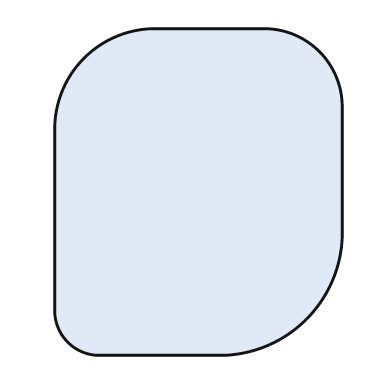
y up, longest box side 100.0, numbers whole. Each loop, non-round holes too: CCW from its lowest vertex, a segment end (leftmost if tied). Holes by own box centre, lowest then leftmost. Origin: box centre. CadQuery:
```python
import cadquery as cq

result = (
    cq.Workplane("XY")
    .moveTo(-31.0, -50.0)
    .lineTo(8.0, -50.0)
    .threePointArc((33.0, -39.0), (44.0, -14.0))
    .lineTo(44.0, 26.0)
    .threePointArc((37.0, 43.0), (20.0, 50.0))
    .lineTo(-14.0, 50.0)
    .threePointArc((-35.0, 41.0), (-44.0, 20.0))
    .lineTo(-44.0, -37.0)
    .threePointArc((-40.0, -46.0), (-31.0, -50.0))
    .close()
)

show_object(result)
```